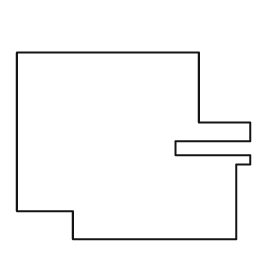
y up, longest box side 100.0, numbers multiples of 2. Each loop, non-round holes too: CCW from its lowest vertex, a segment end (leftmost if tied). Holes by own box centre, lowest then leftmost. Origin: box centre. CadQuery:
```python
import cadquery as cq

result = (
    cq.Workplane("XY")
    .moveTo(-26.0, -40.0)
    .lineTo(44.0, -40.0)
    .lineTo(44.0, -8.0)
    .lineTo(50.0, -8.0)
    .lineTo(50.0, -4.0)
    .lineTo(18.0, -4.0)
    .lineTo(18.0, 2.0)
    .lineTo(50.0, 2.0)
    .lineTo(50.0, 10.0)
    .lineTo(28.0, 10.0)
    .lineTo(28.0, 40.0)
    .lineTo(-50.0, 40.0)
    .lineTo(-50.0, -28.0)
    .lineTo(-26.0, -28.0)
    .close()
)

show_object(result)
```